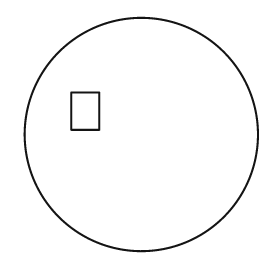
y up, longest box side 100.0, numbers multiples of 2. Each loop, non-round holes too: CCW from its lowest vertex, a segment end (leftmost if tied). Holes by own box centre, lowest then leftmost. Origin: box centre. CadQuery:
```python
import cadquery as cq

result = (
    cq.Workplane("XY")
    .moveTo(0.0, 0.0)
    .circle(50.0)
    .moveTo(-30.0, 2.0)
    .lineTo(-18.0, 2.0)
    .lineTo(-18.0, 18.0)
    .lineTo(-30.0, 18.0)
    .close()
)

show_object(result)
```